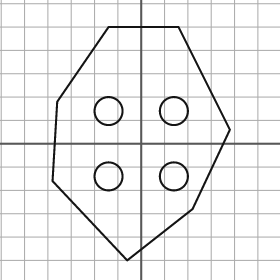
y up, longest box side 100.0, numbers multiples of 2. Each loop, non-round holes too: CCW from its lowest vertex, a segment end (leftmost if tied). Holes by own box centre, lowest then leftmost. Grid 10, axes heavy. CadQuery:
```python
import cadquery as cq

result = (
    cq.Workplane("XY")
    .moveTo(-6.0, -50.0)
    .lineTo(22.0, -28.0)
    .lineTo(38.0, 6.0)
    .lineTo(16.0, 50.0)
    .lineTo(-14.0, 50.0)
    .lineTo(-36.0, 18.0)
    .lineTo(-38.0, -16.0)
    .close()
    .moveTo(-14.0, -14.0)
    .circle(6.0)
    .moveTo(14.0, -14.0)
    .circle(6.0)
    .moveTo(-14.0, 14.0)
    .circle(6.0)
    .moveTo(14.0, 14.0)
    .circle(6.0)
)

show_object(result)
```